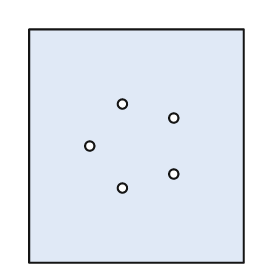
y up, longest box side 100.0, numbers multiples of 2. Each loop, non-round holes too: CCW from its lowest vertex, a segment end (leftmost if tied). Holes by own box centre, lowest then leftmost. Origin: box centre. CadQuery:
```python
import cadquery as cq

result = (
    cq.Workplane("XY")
    .moveTo(-46.0, -50.0)
    .lineTo(46.0, -50.0)
    .lineTo(46.0, 50.0)
    .lineTo(-46.0, 50.0)
    .close()
    .moveTo(-6.0, -18.0)
    .circle(2.0)
    .moveTo(16.0, -12.0)
    .circle(2.0)
    .moveTo(-20.0, 0.0)
    .circle(2.0)
    .moveTo(16.0, 12.0)
    .circle(2.0)
    .moveTo(-6.0, 18.0)
    .circle(2.0)
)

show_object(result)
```